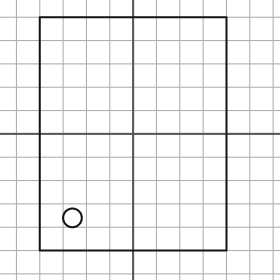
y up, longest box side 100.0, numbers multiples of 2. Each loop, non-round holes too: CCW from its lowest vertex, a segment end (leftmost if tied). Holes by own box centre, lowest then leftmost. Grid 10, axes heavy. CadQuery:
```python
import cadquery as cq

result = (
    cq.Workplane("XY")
    .moveTo(-40.0, -50.0)
    .lineTo(40.0, -50.0)
    .lineTo(40.0, 50.0)
    .lineTo(-40.0, 50.0)
    .close()
    .moveTo(-26.0, -36.0)
    .circle(4.0)
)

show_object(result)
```